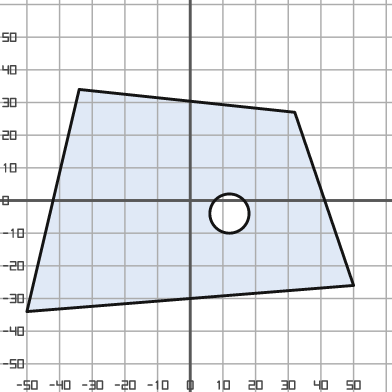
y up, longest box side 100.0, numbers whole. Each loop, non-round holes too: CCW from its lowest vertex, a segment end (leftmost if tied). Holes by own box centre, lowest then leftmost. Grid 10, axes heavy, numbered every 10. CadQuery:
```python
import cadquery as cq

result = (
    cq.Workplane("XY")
    .moveTo(-50.0, -34.0)
    .lineTo(50.0, -26.0)
    .lineTo(32.0, 27.0)
    .lineTo(-34.0, 34.0)
    .close()
    .moveTo(12.0, -4.0)
    .circle(6.0)
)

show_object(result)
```